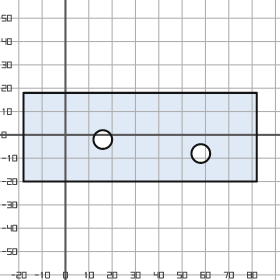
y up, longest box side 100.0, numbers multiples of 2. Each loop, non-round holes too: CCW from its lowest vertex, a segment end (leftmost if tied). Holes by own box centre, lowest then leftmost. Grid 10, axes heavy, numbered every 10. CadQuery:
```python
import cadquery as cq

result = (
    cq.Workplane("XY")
    .moveTo(-18.0, -20.0)
    .lineTo(82.0, -20.0)
    .lineTo(82.0, 18.0)
    .lineTo(-18.0, 18.0)
    .close()
    .moveTo(58.0, -8.0)
    .circle(4.0)
    .moveTo(16.0, -2.0)
    .circle(4.0)
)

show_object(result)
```